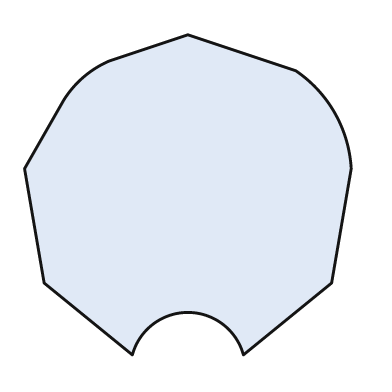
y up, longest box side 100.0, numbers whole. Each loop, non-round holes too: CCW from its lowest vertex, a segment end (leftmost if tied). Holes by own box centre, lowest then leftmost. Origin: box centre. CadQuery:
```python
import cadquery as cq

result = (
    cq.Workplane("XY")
    .moveTo(-17.0, -49.0)
    .threePointArc((0.0, -36.0), (17.0, -49.0))
    .lineTo(44.0, -27.0)
    .lineTo(50.0, 8.0)
    .threePointArc((45.0, 25.0), (33.0, 38.0))
    .lineTo(0.0, 49.0)
    .lineTo(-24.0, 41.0)
    .threePointArc((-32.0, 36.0), (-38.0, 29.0))
    .lineTo(-50.0, 8.0)
    .lineTo(-44.0, -27.0)
    .close()
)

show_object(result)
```